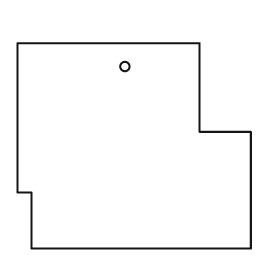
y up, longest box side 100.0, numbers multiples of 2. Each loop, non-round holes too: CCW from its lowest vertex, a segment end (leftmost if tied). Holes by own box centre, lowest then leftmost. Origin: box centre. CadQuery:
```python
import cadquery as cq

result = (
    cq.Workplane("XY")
    .moveTo(-44.0, -44.0)
    .lineTo(50.0, -44.0)
    .lineTo(50.0, 6.0)
    .lineTo(28.0, 6.0)
    .lineTo(28.0, 44.0)
    .lineTo(-50.0, 44.0)
    .lineTo(-50.0, -20.0)
    .lineTo(-44.0, -20.0)
    .close()
    .moveTo(-4.0, 34.0)
    .circle(2.0)
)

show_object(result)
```